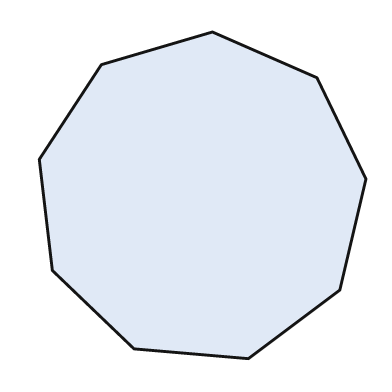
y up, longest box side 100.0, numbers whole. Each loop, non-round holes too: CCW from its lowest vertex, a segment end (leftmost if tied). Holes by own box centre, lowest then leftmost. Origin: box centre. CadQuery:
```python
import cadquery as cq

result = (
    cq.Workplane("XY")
    .moveTo(14.0, -50.0)
    .lineTo(42.0, -29.0)
    .lineTo(50.0, 5.0)
    .lineTo(35.0, 36.0)
    .lineTo(3.0, 50.0)
    .lineTo(-31.0, 40.0)
    .lineTo(-50.0, 11.0)
    .lineTo(-46.0, -23.0)
    .lineTo(-21.0, -47.0)
    .close()
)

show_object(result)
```